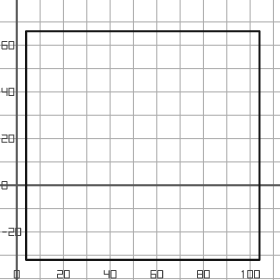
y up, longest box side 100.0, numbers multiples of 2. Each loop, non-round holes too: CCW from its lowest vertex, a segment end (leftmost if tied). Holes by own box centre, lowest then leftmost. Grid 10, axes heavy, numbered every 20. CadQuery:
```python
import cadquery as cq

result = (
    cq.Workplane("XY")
    .moveTo(4.0, -32.0)
    .lineTo(104.0, -32.0)
    .lineTo(104.0, 66.0)
    .lineTo(4.0, 66.0)
    .close()
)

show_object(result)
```